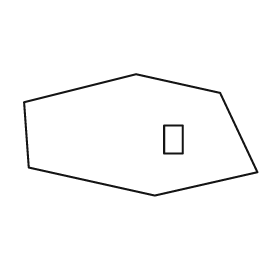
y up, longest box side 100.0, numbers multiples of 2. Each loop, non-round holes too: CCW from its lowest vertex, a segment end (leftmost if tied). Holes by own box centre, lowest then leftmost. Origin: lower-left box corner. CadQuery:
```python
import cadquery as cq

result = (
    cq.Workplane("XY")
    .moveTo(56.0, 0.0)
    .lineTo(100.0, 10.0)
    .lineTo(84.0, 44.0)
    .lineTo(48.0, 52.0)
    .lineTo(0.0, 40.0)
    .lineTo(2.0, 12.0)
    .close()
    .moveTo(60.0, 18.0)
    .lineTo(68.0, 18.0)
    .lineTo(68.0, 30.0)
    .lineTo(60.0, 30.0)
    .close()
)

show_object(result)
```